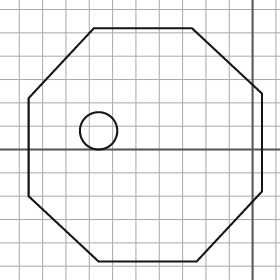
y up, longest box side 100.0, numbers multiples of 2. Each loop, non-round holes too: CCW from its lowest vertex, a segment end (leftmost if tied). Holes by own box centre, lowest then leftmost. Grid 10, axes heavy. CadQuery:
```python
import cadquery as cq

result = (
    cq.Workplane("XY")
    .moveTo(-66.0, -48.0)
    .lineTo(-24.0, -48.0)
    .lineTo(4.0, -18.0)
    .lineTo(4.0, 24.0)
    .lineTo(-26.0, 52.0)
    .lineTo(-68.0, 52.0)
    .lineTo(-96.0, 22.0)
    .lineTo(-96.0, -20.0)
    .close()
    .moveTo(-66.0, 8.0)
    .circle(8.0)
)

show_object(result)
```